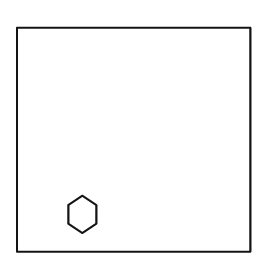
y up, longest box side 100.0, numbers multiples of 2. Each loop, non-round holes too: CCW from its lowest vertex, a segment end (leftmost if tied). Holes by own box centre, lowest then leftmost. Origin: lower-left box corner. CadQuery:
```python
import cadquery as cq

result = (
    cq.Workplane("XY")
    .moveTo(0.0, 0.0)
    .lineTo(100.0, 0.0)
    .lineTo(100.0, 96.0)
    .lineTo(0.0, 96.0)
    .close()
    .moveTo(28.0, 8.0)
    .lineTo(34.0, 12.0)
    .lineTo(34.0, 20.0)
    .lineTo(28.0, 24.0)
    .lineTo(22.0, 20.0)
    .lineTo(22.0, 12.0)
    .close()
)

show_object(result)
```